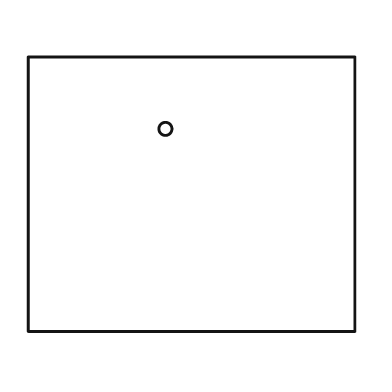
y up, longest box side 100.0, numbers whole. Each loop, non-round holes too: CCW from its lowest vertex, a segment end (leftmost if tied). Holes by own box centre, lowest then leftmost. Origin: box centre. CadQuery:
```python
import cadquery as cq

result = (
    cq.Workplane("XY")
    .moveTo(-50.0, -42.0)
    .lineTo(50.0, -42.0)
    .lineTo(50.0, 42.0)
    .lineTo(-50.0, 42.0)
    .close()
    .moveTo(-8.0, 20.0)
    .circle(2.0)
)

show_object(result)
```